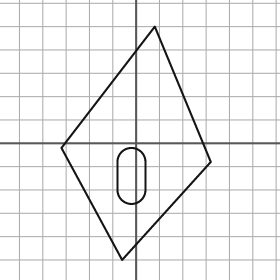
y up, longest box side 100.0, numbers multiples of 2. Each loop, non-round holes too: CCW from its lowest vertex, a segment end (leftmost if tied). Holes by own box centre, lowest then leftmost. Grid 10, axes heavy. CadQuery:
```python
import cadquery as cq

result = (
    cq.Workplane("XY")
    .moveTo(-6.0, -50.0)
    .lineTo(32.0, -8.0)
    .lineTo(8.0, 50.0)
    .lineTo(-32.0, -2.0)
    .close()
    .moveTo(-8.0, -20.0)
    .threePointArc((-2.0, -26.0), (4.0, -20.0))
    .lineTo(4.0, -8.0)
    .threePointArc((-2.0, -2.0), (-8.0, -8.0))
    .close()
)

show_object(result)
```